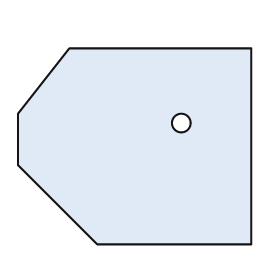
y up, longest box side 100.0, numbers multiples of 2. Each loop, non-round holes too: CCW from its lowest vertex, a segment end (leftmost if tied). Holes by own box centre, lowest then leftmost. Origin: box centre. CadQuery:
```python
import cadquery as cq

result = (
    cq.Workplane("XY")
    .moveTo(-16.0, -42.0)
    .lineTo(50.0, -42.0)
    .lineTo(50.0, 42.0)
    .lineTo(-28.0, 42.0)
    .lineTo(-50.0, 14.0)
    .lineTo(-50.0, -8.0)
    .close()
    .moveTo(20.0, 10.0)
    .circle(4.0)
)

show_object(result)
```